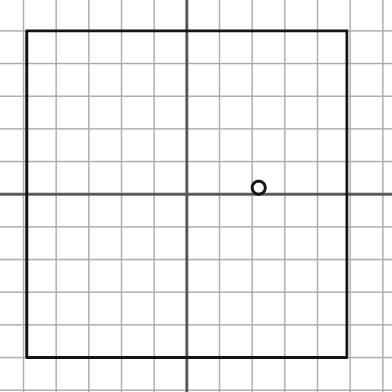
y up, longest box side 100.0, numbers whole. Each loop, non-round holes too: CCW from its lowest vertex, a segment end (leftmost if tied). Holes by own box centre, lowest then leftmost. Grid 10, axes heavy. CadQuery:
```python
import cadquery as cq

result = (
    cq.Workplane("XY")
    .moveTo(-49.0, -50.0)
    .lineTo(49.0, -50.0)
    .lineTo(49.0, 50.0)
    .lineTo(-49.0, 50.0)
    .close()
    .moveTo(22.0, 2.0)
    .circle(2.0)
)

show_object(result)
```